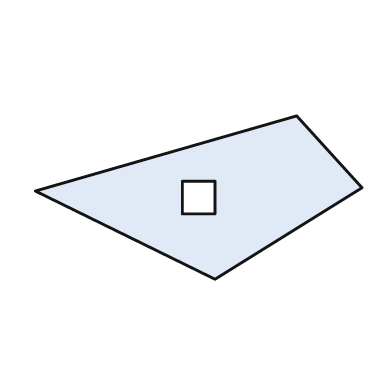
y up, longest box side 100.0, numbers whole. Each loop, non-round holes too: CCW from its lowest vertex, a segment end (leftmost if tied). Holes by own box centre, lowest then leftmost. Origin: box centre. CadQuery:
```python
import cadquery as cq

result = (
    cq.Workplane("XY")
    .moveTo(5.0, -25.0)
    .lineTo(50.0, 3.0)
    .lineTo(30.0, 25.0)
    .lineTo(-50.0, 2.0)
    .close()
    .moveTo(-5.0, -5.0)
    .lineTo(5.0, -5.0)
    .lineTo(5.0, 5.0)
    .lineTo(-5.0, 5.0)
    .close()
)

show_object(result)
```